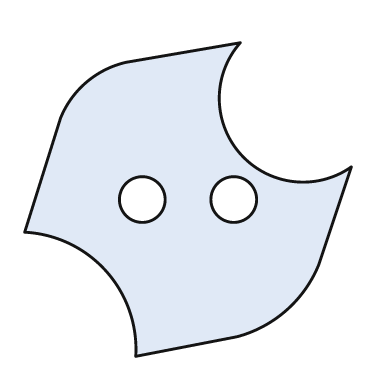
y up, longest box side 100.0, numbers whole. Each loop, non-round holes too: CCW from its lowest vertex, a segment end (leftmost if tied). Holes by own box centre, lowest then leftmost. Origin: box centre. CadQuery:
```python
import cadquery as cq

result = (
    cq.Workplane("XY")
    .moveTo(-16.0, -48.0)
    .lineTo(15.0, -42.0)
    .threePointArc((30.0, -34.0), (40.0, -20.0))
    .lineTo(50.0, 10.0)
    .threePointArc((16.0, 14.0), (16.0, 48.0))
    .lineTo(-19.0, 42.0)
    .threePointArc((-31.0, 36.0), (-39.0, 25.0))
    .lineTo(-50.0, -10.0)
    .threePointArc((-25.0, -22.0), (-16.0, -48.0))
    .close()
    .moveTo(-14.0, 0.0)
    .circle(7.0)
    .moveTo(14.0, 0.0)
    .circle(7.0)
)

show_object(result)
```